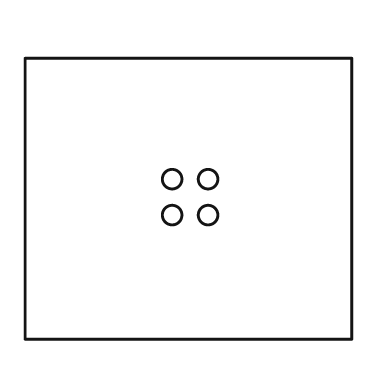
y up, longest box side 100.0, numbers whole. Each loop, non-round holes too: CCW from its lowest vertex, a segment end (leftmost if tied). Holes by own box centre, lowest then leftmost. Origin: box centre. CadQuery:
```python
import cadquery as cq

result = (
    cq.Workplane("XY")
    .moveTo(-50.0, -43.0)
    .lineTo(50.0, -43.0)
    .lineTo(50.0, 43.0)
    .lineTo(-50.0, 43.0)
    .close()
    .moveTo(-5.0, -5.0)
    .circle(3.0)
    .moveTo(6.0, -5.0)
    .circle(3.0)
    .moveTo(-5.0, 6.0)
    .circle(3.0)
    .moveTo(6.0, 6.0)
    .circle(3.0)
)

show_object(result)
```